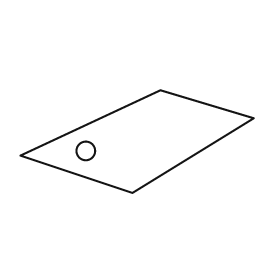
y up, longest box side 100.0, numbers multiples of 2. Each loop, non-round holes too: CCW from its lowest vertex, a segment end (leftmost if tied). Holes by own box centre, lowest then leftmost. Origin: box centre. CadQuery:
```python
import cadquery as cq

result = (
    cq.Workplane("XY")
    .moveTo(-2.0, -22.0)
    .lineTo(50.0, 10.0)
    .lineTo(10.0, 22.0)
    .lineTo(-50.0, -6.0)
    .close()
    .moveTo(-22.0, -4.0)
    .circle(4.0)
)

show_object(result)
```